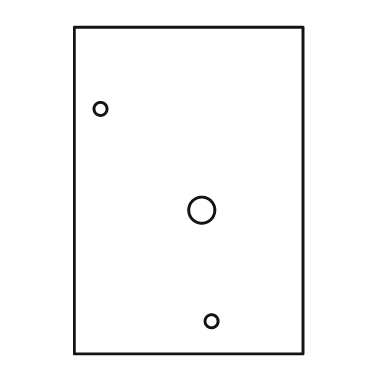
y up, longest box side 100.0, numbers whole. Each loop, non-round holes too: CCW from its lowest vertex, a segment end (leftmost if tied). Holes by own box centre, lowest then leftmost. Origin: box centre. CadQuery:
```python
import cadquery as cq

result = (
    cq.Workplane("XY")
    .moveTo(-35.0, -50.0)
    .lineTo(35.0, -50.0)
    .lineTo(35.0, 50.0)
    .lineTo(-35.0, 50.0)
    .close()
    .moveTo(7.0, -40.0)
    .circle(2.0)
    .moveTo(4.0, -6.0)
    .circle(4.0)
    .moveTo(-27.0, 25.0)
    .circle(2.0)
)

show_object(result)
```